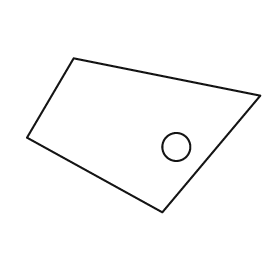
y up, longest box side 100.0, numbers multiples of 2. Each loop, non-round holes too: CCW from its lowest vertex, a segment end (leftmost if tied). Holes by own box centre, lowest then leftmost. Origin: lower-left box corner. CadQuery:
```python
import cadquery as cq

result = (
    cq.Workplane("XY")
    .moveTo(58.0, 0.0)
    .lineTo(100.0, 50.0)
    .lineTo(20.0, 66.0)
    .lineTo(0.0, 32.0)
    .close()
    .moveTo(64.0, 28.0)
    .circle(6.0)
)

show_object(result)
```